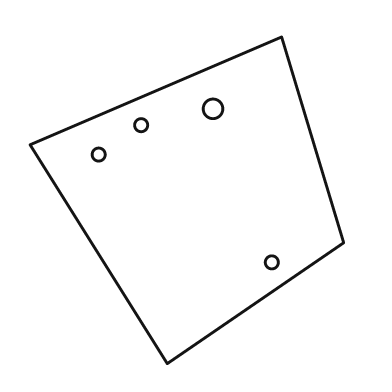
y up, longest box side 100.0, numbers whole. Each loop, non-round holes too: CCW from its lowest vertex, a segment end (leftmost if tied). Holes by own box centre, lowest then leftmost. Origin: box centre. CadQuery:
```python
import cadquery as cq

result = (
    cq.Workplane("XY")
    .moveTo(-6.0, -50.0)
    .lineTo(48.0, -13.0)
    .lineTo(29.0, 50.0)
    .lineTo(-48.0, 17.0)
    .close()
    .moveTo(26.0, -19.0)
    .circle(2.0)
    .moveTo(-27.0, 14.0)
    .circle(2.0)
    .moveTo(-14.0, 23.0)
    .circle(2.0)
    .moveTo(8.0, 28.0)
    .circle(3.0)
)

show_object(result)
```